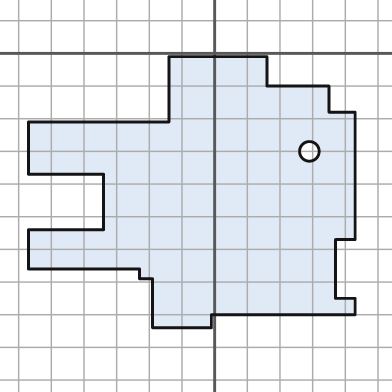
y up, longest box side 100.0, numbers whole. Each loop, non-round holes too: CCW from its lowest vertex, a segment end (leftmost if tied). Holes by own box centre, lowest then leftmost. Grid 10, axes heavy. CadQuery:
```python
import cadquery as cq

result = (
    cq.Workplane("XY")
    .moveTo(-19.0, -84.0)
    .lineTo(-1.0, -84.0)
    .lineTo(-1.0, -80.0)
    .lineTo(43.0, -80.0)
    .lineTo(43.0, -75.0)
    .lineTo(37.0, -75.0)
    .lineTo(37.0, -57.0)
    .lineTo(43.0, -57.0)
    .lineTo(43.0, -18.0)
    .lineTo(35.0, -18.0)
    .lineTo(35.0, -10.0)
    .lineTo(16.0, -10.0)
    .lineTo(16.0, -1.0)
    .lineTo(-14.0, -1.0)
    .lineTo(-14.0, -21.0)
    .lineTo(-57.0, -21.0)
    .lineTo(-57.0, -37.0)
    .lineTo(-34.0, -37.0)
    .lineTo(-34.0, -54.0)
    .lineTo(-57.0, -54.0)
    .lineTo(-57.0, -66.0)
    .lineTo(-23.0, -66.0)
    .lineTo(-23.0, -69.0)
    .lineTo(-19.0, -69.0)
    .close()
    .moveTo(29.0, -30.0)
    .circle(3.0)
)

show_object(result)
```